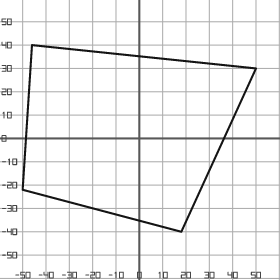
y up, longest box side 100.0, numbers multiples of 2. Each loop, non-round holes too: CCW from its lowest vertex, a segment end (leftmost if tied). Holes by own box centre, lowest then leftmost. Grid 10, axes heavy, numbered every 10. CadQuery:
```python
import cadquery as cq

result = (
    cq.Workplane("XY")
    .moveTo(18.0, -40.0)
    .lineTo(50.0, 30.0)
    .lineTo(-46.0, 40.0)
    .lineTo(-50.0, -22.0)
    .close()
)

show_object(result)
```